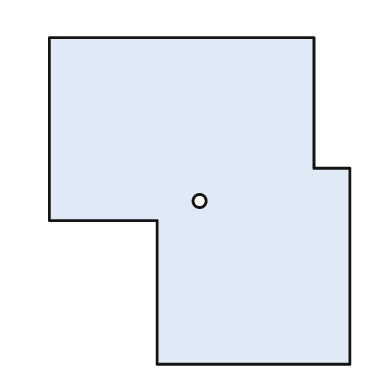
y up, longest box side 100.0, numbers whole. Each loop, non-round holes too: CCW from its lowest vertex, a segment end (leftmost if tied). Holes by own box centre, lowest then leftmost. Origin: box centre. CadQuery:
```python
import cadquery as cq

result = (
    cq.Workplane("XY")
    .moveTo(-13.0, -50.0)
    .lineTo(46.0, -50.0)
    .lineTo(46.0, 10.0)
    .lineTo(35.0, 10.0)
    .lineTo(35.0, 50.0)
    .lineTo(-46.0, 50.0)
    .lineTo(-46.0, -6.0)
    .lineTo(-13.0, -6.0)
    .close()
    .moveTo(0.0, 0.0)
    .circle(2.0)
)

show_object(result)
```